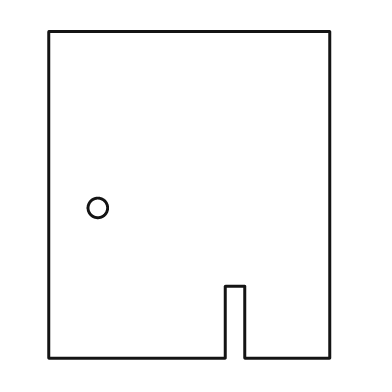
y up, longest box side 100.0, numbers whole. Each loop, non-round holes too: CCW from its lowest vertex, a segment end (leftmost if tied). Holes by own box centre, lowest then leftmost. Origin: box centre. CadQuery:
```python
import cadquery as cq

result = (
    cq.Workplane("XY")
    .moveTo(-43.0, -50.0)
    .lineTo(11.0, -50.0)
    .lineTo(11.0, -28.0)
    .lineTo(17.0, -28.0)
    .lineTo(17.0, -50.0)
    .lineTo(43.0, -50.0)
    .lineTo(43.0, 50.0)
    .lineTo(-43.0, 50.0)
    .close()
    .moveTo(-28.0, -4.0)
    .circle(3.0)
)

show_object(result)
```